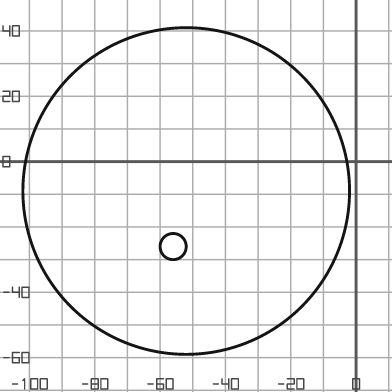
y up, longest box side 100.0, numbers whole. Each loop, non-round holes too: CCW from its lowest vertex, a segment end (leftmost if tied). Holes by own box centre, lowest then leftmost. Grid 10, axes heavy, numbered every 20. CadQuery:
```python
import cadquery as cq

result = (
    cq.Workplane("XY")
    .moveTo(-52.0, -9.0)
    .circle(50.0)
    .moveTo(-56.0, -26.0)
    .circle(4.0)
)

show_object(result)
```